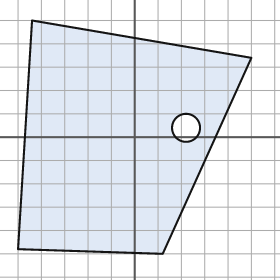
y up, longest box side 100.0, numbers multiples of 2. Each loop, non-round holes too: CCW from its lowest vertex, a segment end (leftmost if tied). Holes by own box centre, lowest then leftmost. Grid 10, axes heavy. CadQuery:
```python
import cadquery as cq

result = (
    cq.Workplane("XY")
    .moveTo(12.0, -50.0)
    .lineTo(50.0, 34.0)
    .lineTo(-44.0, 50.0)
    .lineTo(-50.0, -48.0)
    .close()
    .moveTo(22.0, 4.0)
    .circle(6.0)
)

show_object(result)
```